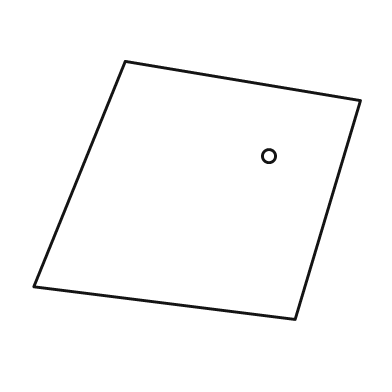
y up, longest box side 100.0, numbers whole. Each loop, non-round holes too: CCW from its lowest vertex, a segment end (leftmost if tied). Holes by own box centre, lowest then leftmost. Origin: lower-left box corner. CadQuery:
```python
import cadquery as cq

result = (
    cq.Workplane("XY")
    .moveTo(80.0, 0.0)
    .lineTo(100.0, 67.0)
    .lineTo(28.0, 79.0)
    .lineTo(0.0, 10.0)
    .close()
    .moveTo(72.0, 50.0)
    .circle(2.0)
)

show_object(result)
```